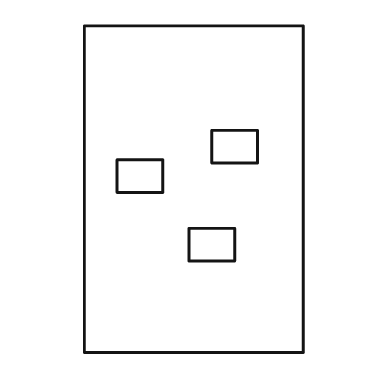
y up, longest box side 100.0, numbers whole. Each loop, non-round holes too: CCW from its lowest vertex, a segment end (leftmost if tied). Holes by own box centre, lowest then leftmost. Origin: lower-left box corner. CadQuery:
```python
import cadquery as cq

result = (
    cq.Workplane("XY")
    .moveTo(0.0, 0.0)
    .lineTo(67.0, 0.0)
    .lineTo(67.0, 100.0)
    .lineTo(0.0, 100.0)
    .close()
    .moveTo(32.0, 28.0)
    .lineTo(46.0, 28.0)
    .lineTo(46.0, 38.0)
    .lineTo(32.0, 38.0)
    .close()
    .moveTo(10.0, 49.0)
    .lineTo(24.0, 49.0)
    .lineTo(24.0, 59.0)
    .lineTo(10.0, 59.0)
    .close()
    .moveTo(39.0, 58.0)
    .lineTo(53.0, 58.0)
    .lineTo(53.0, 68.0)
    .lineTo(39.0, 68.0)
    .close()
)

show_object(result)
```